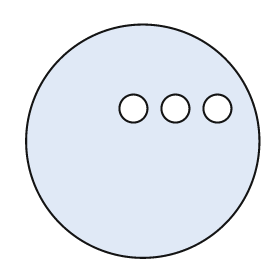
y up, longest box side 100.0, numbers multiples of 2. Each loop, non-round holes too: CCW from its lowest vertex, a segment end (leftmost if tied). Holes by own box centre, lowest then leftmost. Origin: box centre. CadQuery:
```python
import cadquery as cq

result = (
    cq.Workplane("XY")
    .moveTo(0.0, 0.0)
    .circle(50.0)
    .moveTo(-4.0, 14.0)
    .circle(6.0)
    .moveTo(14.0, 14.0)
    .circle(6.0)
    .moveTo(32.0, 14.0)
    .circle(6.0)
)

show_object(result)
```